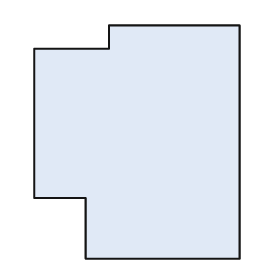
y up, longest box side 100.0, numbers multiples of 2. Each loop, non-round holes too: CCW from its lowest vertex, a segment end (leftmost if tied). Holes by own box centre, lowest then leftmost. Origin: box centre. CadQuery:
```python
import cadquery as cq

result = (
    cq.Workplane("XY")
    .moveTo(-22.0, -50.0)
    .lineTo(44.0, -50.0)
    .lineTo(44.0, 50.0)
    .lineTo(-12.0, 50.0)
    .lineTo(-12.0, 40.0)
    .lineTo(-44.0, 40.0)
    .lineTo(-44.0, -24.0)
    .lineTo(-22.0, -24.0)
    .close()
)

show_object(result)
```